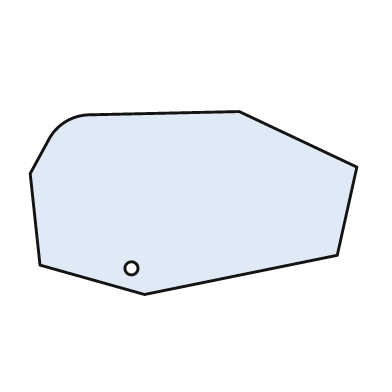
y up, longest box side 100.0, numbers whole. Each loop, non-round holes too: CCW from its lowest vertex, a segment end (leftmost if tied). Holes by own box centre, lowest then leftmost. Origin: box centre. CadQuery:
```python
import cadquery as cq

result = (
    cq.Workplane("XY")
    .moveTo(-15.0, -28.0)
    .lineTo(44.0, -16.0)
    .lineTo(50.0, 11.0)
    .lineTo(14.0, 28.0)
    .lineTo(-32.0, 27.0)
    .threePointArc((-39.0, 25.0), (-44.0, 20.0))
    .lineTo(-50.0, 9.0)
    .lineTo(-47.0, -19.0)
    .close()
    .moveTo(-19.0, -20.0)
    .circle(2.0)
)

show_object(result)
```